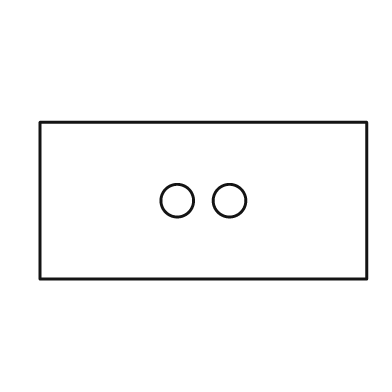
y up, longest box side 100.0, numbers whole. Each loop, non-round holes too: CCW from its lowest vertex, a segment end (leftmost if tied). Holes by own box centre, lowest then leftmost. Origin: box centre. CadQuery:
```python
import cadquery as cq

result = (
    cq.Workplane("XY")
    .moveTo(-50.0, -24.0)
    .lineTo(50.0, -24.0)
    .lineTo(50.0, 24.0)
    .lineTo(-50.0, 24.0)
    .close()
    .moveTo(-8.0, 0.0)
    .circle(5.0)
    .moveTo(8.0, 0.0)
    .circle(5.0)
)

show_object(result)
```